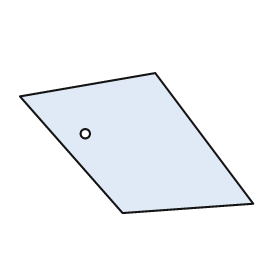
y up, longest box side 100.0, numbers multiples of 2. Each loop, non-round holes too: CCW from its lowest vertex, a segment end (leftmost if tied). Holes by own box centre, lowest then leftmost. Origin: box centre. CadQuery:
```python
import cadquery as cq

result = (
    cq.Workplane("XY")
    .moveTo(-6.0, -30.0)
    .lineTo(50.0, -26.0)
    .lineTo(8.0, 30.0)
    .lineTo(-50.0, 20.0)
    .close()
    .moveTo(-22.0, 4.0)
    .circle(2.0)
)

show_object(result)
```